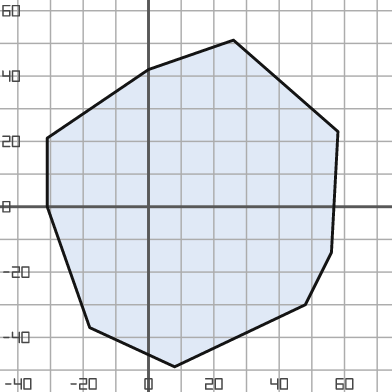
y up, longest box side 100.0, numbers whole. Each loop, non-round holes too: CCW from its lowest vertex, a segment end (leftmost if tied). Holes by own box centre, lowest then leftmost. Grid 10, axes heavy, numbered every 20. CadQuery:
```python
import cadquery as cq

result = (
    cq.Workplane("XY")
    .moveTo(8.0, -49.0)
    .lineTo(48.0, -30.0)
    .lineTo(56.0, -14.0)
    .lineTo(58.0, 23.0)
    .lineTo(26.0, 51.0)
    .lineTo(0.0, 42.0)
    .lineTo(-31.0, 21.0)
    .lineTo(-31.0, 0.0)
    .lineTo(-18.0, -37.0)
    .close()
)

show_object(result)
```